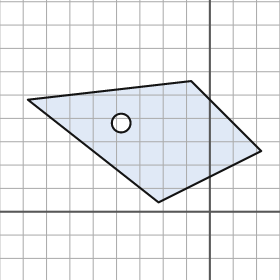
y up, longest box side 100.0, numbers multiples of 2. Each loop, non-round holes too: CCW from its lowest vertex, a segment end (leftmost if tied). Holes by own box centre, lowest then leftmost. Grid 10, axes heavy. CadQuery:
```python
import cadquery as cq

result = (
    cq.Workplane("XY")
    .moveTo(-22.0, 4.0)
    .lineTo(22.0, 26.0)
    .lineTo(-8.0, 56.0)
    .lineTo(-78.0, 48.0)
    .close()
    .moveTo(-38.0, 38.0)
    .circle(4.0)
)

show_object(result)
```